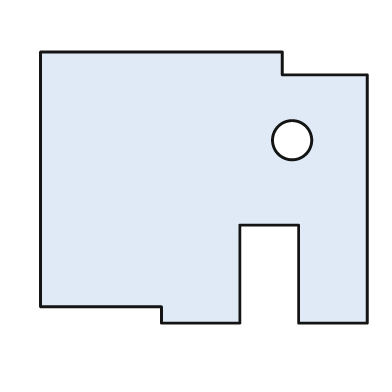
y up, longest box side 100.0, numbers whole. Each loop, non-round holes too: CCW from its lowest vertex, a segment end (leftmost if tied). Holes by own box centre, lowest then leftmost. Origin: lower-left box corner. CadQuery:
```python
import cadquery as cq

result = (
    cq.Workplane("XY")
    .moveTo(37.0, 0.0)
    .lineTo(61.0, 0.0)
    .lineTo(61.0, 30.0)
    .lineTo(79.0, 30.0)
    .lineTo(79.0, 0.0)
    .lineTo(100.0, 0.0)
    .lineTo(100.0, 76.0)
    .lineTo(74.0, 76.0)
    .lineTo(74.0, 83.0)
    .lineTo(0.0, 83.0)
    .lineTo(0.0, 5.0)
    .lineTo(37.0, 5.0)
    .close()
    .moveTo(77.0, 56.0)
    .circle(6.0)
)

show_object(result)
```